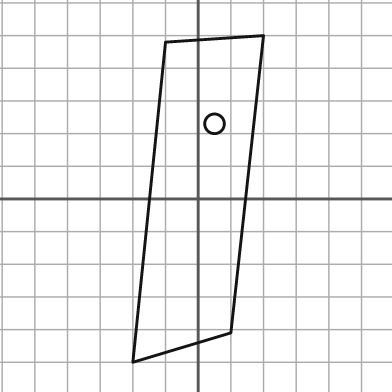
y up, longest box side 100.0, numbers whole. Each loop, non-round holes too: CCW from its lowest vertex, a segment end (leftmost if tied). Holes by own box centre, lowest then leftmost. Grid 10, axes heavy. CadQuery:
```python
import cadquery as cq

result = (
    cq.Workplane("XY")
    .moveTo(-20.0, -50.0)
    .lineTo(10.0, -41.0)
    .lineTo(20.0, 50.0)
    .lineTo(-10.0, 48.0)
    .close()
    .moveTo(5.0, 23.0)
    .circle(3.0)
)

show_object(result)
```